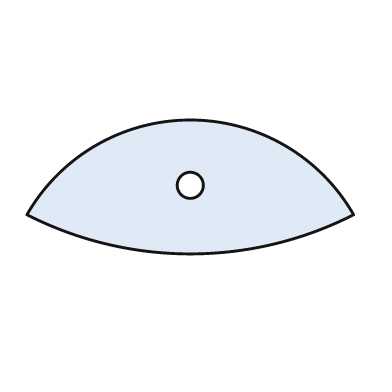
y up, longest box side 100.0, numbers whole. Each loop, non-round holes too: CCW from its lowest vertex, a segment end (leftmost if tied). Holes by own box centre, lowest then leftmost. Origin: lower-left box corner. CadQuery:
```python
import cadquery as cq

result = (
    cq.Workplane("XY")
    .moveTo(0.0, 12.0)
    .threePointArc((50.0, 0.0), (100.0, 12.0))
    .threePointArc((50.0, 41.0), (0.0, 12.0))
    .close()
    .moveTo(50.0, 21.0)
    .circle(4.0)
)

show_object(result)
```